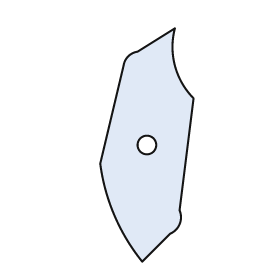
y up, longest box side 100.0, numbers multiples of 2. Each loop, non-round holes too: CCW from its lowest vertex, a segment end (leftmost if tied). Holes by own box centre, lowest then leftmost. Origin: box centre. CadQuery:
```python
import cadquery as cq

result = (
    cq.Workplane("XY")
    .moveTo(-2.0, -50.0)
    .lineTo(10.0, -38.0)
    .threePointArc((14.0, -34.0), (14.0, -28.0))
    .lineTo(20.0, 20.0)
    .threePointArc((12.0, 34.0), (12.0, 50.0))
    .lineTo(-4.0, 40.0)
    .threePointArc((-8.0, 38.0), (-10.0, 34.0))
    .lineTo(-20.0, -8.0)
    .threePointArc((-14.0, -30.0), (-2.0, -50.0))
    .close()
    .moveTo(0.0, 0.0)
    .circle(4.0)
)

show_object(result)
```